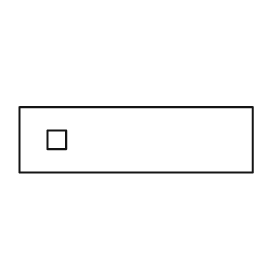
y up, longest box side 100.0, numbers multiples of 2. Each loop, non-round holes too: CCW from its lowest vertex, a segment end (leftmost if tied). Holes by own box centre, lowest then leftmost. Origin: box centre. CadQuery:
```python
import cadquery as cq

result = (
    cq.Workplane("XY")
    .moveTo(-50.0, -14.0)
    .lineTo(50.0, -14.0)
    .lineTo(50.0, 14.0)
    .lineTo(-50.0, 14.0)
    .close()
    .moveTo(-38.0, -4.0)
    .lineTo(-30.0, -4.0)
    .lineTo(-30.0, 4.0)
    .lineTo(-38.0, 4.0)
    .close()
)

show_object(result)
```